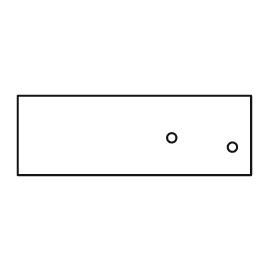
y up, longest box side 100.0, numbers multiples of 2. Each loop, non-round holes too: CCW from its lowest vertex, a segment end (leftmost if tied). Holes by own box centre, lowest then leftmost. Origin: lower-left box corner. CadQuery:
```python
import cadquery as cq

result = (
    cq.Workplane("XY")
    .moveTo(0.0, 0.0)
    .lineTo(100.0, 0.0)
    .lineTo(100.0, 34.0)
    .lineTo(0.0, 34.0)
    .close()
    .moveTo(92.0, 12.0)
    .circle(2.0)
    .moveTo(66.0, 16.0)
    .circle(2.0)
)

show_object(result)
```